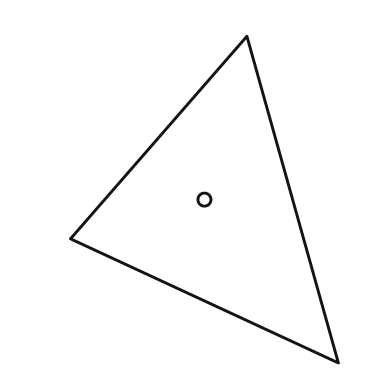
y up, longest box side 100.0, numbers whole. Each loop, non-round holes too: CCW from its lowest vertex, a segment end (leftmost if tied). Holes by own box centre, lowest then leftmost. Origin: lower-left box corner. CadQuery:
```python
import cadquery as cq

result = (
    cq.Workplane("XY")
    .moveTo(82.0, 0.0)
    .lineTo(54.0, 100.0)
    .lineTo(0.0, 38.0)
    .close()
    .moveTo(41.0, 50.0)
    .circle(2.0)
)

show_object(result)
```